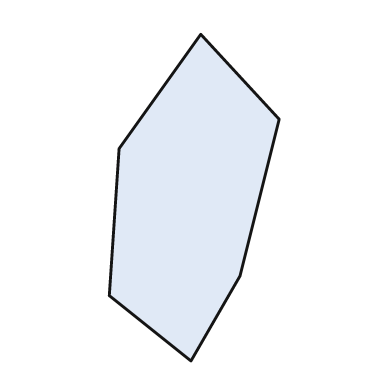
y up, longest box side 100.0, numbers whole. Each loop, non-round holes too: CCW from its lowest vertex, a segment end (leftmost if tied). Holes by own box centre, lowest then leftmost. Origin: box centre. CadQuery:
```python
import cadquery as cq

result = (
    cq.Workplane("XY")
    .moveTo(-1.0, -50.0)
    .lineTo(14.0, -24.0)
    .lineTo(26.0, 24.0)
    .lineTo(2.0, 50.0)
    .lineTo(-23.0, 15.0)
    .lineTo(-26.0, -30.0)
    .close()
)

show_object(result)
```